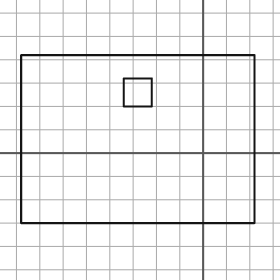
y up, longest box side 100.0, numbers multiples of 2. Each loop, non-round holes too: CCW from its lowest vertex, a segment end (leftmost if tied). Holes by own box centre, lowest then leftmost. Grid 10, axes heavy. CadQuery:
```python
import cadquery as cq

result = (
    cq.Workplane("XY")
    .moveTo(-78.0, -30.0)
    .lineTo(22.0, -30.0)
    .lineTo(22.0, 42.0)
    .lineTo(-78.0, 42.0)
    .close()
    .moveTo(-34.0, 20.0)
    .lineTo(-22.0, 20.0)
    .lineTo(-22.0, 32.0)
    .lineTo(-34.0, 32.0)
    .close()
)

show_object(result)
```